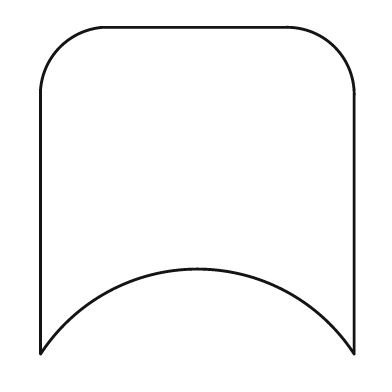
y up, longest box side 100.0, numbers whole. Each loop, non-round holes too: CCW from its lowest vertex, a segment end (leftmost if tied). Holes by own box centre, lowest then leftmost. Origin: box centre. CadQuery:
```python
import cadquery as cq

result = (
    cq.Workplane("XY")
    .moveTo(-48.0, -50.0)
    .threePointArc((0.0, -24.0), (48.0, -50.0))
    .lineTo(48.0, 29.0)
    .threePointArc((42.0, 44.0), (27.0, 50.0))
    .lineTo(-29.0, 50.0)
    .threePointArc((-42.0, 44.0), (-48.0, 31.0))
    .close()
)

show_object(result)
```